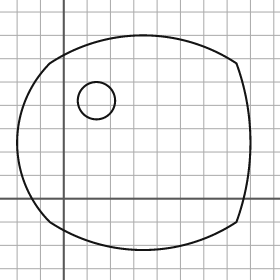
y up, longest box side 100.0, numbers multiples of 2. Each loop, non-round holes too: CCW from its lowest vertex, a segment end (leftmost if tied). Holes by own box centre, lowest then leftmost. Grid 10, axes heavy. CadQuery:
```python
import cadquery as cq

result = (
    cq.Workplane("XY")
    .moveTo(-6.0, -10.0)
    .threePointArc((34.0, -22.0), (74.0, -10.0))
    .threePointArc((80.0, 24.0), (74.0, 58.0))
    .threePointArc((34.0, 70.0), (-6.0, 58.0))
    .threePointArc((-20.0, 24.0), (-6.0, -10.0))
    .close()
    .moveTo(14.0, 42.0)
    .circle(8.0)
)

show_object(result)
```